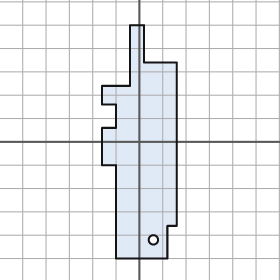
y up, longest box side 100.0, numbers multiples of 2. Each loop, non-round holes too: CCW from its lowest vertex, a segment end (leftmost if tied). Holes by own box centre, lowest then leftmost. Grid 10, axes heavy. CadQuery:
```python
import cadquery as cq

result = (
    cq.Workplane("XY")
    .moveTo(-10.0, -50.0)
    .lineTo(12.0, -50.0)
    .lineTo(12.0, -36.0)
    .lineTo(16.0, -36.0)
    .lineTo(16.0, 34.0)
    .lineTo(2.0, 34.0)
    .lineTo(2.0, 50.0)
    .lineTo(-4.0, 50.0)
    .lineTo(-4.0, 24.0)
    .lineTo(-16.0, 24.0)
    .lineTo(-16.0, 16.0)
    .lineTo(-10.0, 16.0)
    .lineTo(-10.0, 6.0)
    .lineTo(-16.0, 6.0)
    .lineTo(-16.0, -10.0)
    .lineTo(-10.0, -10.0)
    .close()
    .moveTo(6.0, -42.0)
    .circle(2.0)
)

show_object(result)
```